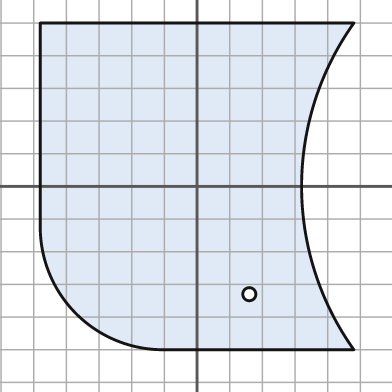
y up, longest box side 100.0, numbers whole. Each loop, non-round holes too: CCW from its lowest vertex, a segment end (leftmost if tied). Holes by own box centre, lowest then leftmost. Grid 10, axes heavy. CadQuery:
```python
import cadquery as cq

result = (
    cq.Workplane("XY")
    .moveTo(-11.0, -50.0)
    .lineTo(48.0, -50.0)
    .threePointArc((32.0, 0.0), (48.0, 50.0))
    .lineTo(-48.0, 50.0)
    .lineTo(-48.0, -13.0)
    .threePointArc((-37.0, -39.0), (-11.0, -50.0))
    .close()
    .moveTo(16.0, -33.0)
    .circle(2.0)
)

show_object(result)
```